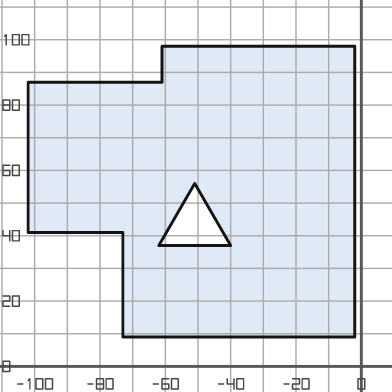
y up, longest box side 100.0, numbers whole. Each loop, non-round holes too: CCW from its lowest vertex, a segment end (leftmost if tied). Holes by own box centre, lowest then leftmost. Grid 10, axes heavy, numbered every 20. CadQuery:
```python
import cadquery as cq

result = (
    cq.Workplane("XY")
    .moveTo(-73.0, 9.0)
    .lineTo(-2.0, 9.0)
    .lineTo(-2.0, 98.0)
    .lineTo(-61.0, 98.0)
    .lineTo(-61.0, 87.0)
    .lineTo(-102.0, 87.0)
    .lineTo(-102.0, 41.0)
    .lineTo(-73.0, 41.0)
    .close()
    .moveTo(-62.0, 37.0)
    .lineTo(-40.0, 37.0)
    .lineTo(-51.0, 56.0)
    .close()
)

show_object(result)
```